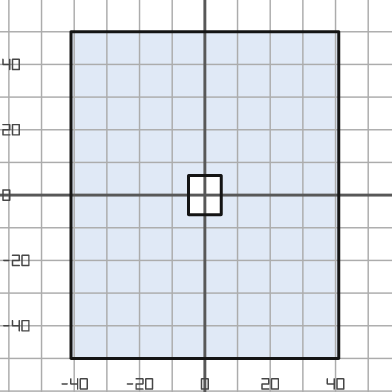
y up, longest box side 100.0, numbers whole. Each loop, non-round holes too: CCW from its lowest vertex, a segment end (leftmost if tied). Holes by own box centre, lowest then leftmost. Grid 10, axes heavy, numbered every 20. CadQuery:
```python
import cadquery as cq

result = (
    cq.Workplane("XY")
    .moveTo(-41.0, -50.0)
    .lineTo(41.0, -50.0)
    .lineTo(41.0, 50.0)
    .lineTo(-41.0, 50.0)
    .close()
    .moveTo(-5.0, -6.0)
    .lineTo(5.0, -6.0)
    .lineTo(5.0, 6.0)
    .lineTo(-5.0, 6.0)
    .close()
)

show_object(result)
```